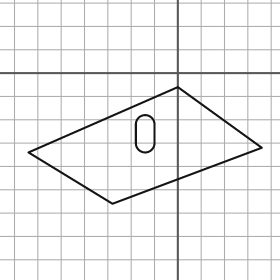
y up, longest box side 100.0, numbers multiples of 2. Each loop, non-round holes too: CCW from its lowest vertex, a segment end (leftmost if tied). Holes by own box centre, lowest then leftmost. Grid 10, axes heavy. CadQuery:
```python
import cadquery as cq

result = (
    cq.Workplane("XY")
    .moveTo(-28.0, -56.0)
    .lineTo(36.0, -32.0)
    .lineTo(0.0, -6.0)
    .lineTo(-64.0, -34.0)
    .close()
    .moveTo(-18.0, -30.0)
    .threePointArc((-14.0, -34.0), (-10.0, -30.0))
    .lineTo(-10.0, -22.0)
    .threePointArc((-14.0, -18.0), (-18.0, -22.0))
    .close()
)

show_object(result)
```